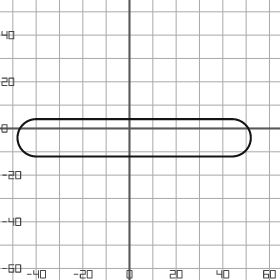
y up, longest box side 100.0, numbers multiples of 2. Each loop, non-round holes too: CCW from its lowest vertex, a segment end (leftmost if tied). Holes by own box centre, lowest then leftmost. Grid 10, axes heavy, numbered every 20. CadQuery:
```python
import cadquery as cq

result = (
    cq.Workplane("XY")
    .moveTo(-40.0, -12.0)
    .lineTo(44.0, -12.0)
    .threePointArc((52.0, -4.0), (44.0, 4.0))
    .lineTo(-40.0, 4.0)
    .threePointArc((-48.0, -4.0), (-40.0, -12.0))
    .close()
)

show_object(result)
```